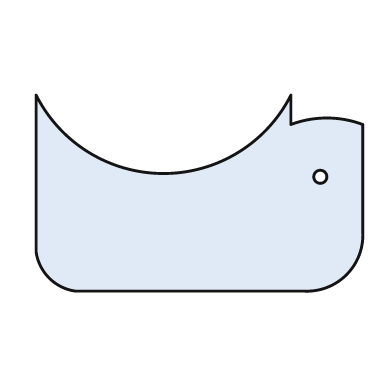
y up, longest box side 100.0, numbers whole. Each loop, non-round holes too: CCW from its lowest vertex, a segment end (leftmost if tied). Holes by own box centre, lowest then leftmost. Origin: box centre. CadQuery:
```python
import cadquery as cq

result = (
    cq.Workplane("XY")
    .moveTo(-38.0, -30.0)
    .lineTo(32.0, -30.0)
    .threePointArc((45.0, -25.0), (50.0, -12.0))
    .lineTo(50.0, 21.0)
    .threePointArc((39.0, 23.0), (28.0, 21.0))
    .lineTo(28.0, 30.0)
    .threePointArc((-11.0, 6.0), (-50.0, 30.0))
    .lineTo(-50.0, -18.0)
    .threePointArc((-46.0, -26.0), (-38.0, -30.0))
    .close()
    .moveTo(37.0, 5.0)
    .circle(2.0)
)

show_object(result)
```